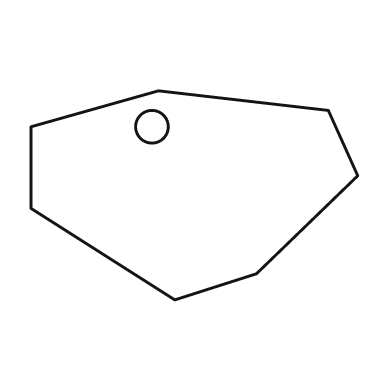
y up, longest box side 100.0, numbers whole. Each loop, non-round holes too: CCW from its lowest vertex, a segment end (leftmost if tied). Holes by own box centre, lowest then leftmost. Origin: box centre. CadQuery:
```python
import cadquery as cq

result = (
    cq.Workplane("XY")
    .moveTo(-6.0, -32.0)
    .lineTo(19.0, -24.0)
    .lineTo(50.0, 6.0)
    .lineTo(41.0, 26.0)
    .lineTo(-11.0, 32.0)
    .lineTo(-50.0, 21.0)
    .lineTo(-50.0, -4.0)
    .close()
    .moveTo(-13.0, 21.0)
    .circle(5.0)
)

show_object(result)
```